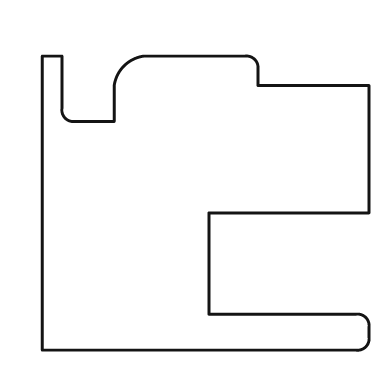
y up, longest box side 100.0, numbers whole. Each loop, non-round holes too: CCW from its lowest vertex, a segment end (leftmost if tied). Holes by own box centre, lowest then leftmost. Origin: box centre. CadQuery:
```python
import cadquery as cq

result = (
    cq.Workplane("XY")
    .moveTo(-50.0, -45.0)
    .lineTo(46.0, -45.0)
    .threePointArc((49.0, -44.0), (50.0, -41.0))
    .lineTo(50.0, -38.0)
    .threePointArc((49.0, -35.0), (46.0, -34.0))
    .lineTo(1.0, -34.0)
    .lineTo(1.0, -3.0)
    .lineTo(50.0, -3.0)
    .lineTo(50.0, 36.0)
    .lineTo(16.0, 36.0)
    .lineTo(16.0, 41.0)
    .threePointArc((15.0, 44.0), (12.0, 45.0))
    .lineTo(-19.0, 45.0)
    .threePointArc((-25.0, 42.0), (-28.0, 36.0))
    .lineTo(-28.0, 25.0)
    .lineTo(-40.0, 25.0)
    .threePointArc((-43.0, 26.0), (-44.0, 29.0))
    .lineTo(-44.0, 45.0)
    .lineTo(-50.0, 45.0)
    .close()
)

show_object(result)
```